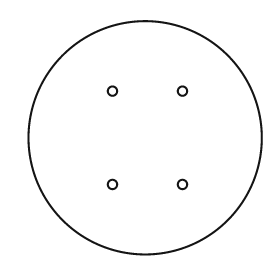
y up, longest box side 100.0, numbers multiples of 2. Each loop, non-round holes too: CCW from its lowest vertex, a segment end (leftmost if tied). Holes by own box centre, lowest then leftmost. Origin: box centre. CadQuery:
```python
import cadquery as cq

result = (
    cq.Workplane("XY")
    .moveTo(0.0, 0.0)
    .circle(50.0)
    .moveTo(-14.0, -20.0)
    .circle(2.0)
    .moveTo(16.0, -20.0)
    .circle(2.0)
    .moveTo(-14.0, 20.0)
    .circle(2.0)
    .moveTo(16.0, 20.0)
    .circle(2.0)
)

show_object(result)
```